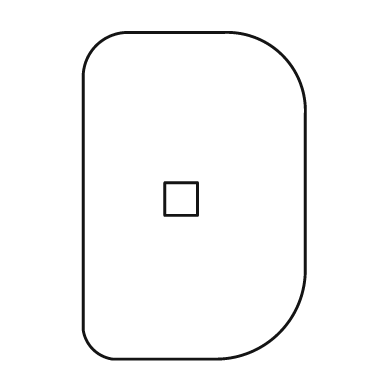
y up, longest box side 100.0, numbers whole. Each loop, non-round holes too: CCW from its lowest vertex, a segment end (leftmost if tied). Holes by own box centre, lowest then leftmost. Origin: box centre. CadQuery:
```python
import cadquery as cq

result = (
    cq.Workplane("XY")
    .moveTo(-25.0, -50.0)
    .lineTo(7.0, -50.0)
    .threePointArc((26.0, -42.0), (34.0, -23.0))
    .lineTo(34.0, 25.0)
    .threePointArc((27.0, 43.0), (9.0, 50.0))
    .lineTo(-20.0, 50.0)
    .threePointArc((-30.0, 46.0), (-34.0, 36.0))
    .lineTo(-34.0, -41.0)
    .threePointArc((-31.0, -47.0), (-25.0, -50.0))
    .close()
    .moveTo(-9.0, -6.0)
    .lineTo(1.0, -6.0)
    .lineTo(1.0, 4.0)
    .lineTo(-9.0, 4.0)
    .close()
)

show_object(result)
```